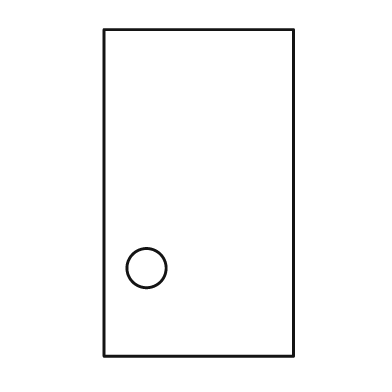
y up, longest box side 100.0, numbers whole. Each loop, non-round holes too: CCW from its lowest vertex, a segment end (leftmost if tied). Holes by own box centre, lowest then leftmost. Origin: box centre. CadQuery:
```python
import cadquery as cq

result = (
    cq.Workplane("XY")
    .moveTo(-29.0, -50.0)
    .lineTo(29.0, -50.0)
    .lineTo(29.0, 50.0)
    .lineTo(-29.0, 50.0)
    .close()
    .moveTo(-16.0, -23.0)
    .circle(6.0)
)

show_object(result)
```